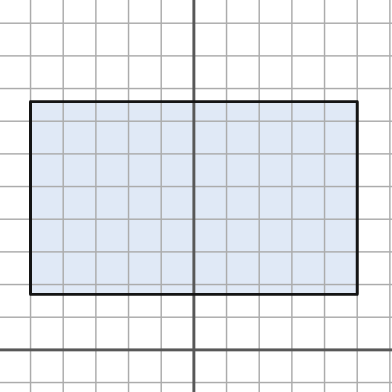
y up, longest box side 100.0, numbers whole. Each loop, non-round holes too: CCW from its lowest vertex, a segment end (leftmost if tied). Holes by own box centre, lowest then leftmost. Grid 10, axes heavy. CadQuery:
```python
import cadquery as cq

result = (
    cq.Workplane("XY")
    .moveTo(-50.0, 17.0)
    .lineTo(50.0, 17.0)
    .lineTo(50.0, 76.0)
    .lineTo(-50.0, 76.0)
    .close()
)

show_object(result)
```